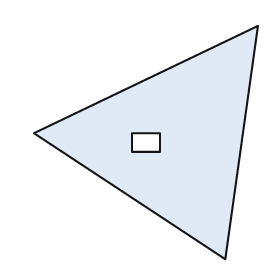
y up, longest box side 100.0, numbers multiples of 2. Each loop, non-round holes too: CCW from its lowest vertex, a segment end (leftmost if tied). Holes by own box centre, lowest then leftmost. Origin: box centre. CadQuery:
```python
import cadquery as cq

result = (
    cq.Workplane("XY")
    .moveTo(34.0, -50.0)
    .lineTo(48.0, 50.0)
    .lineTo(-48.0, 4.0)
    .close()
    .moveTo(-6.0, -4.0)
    .lineTo(6.0, -4.0)
    .lineTo(6.0, 4.0)
    .lineTo(-6.0, 4.0)
    .close()
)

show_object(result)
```